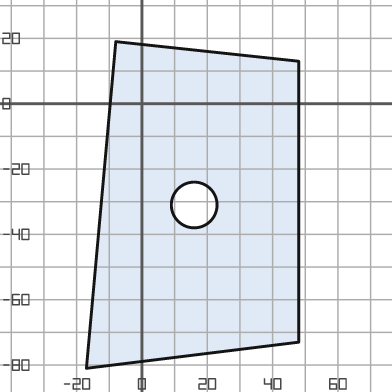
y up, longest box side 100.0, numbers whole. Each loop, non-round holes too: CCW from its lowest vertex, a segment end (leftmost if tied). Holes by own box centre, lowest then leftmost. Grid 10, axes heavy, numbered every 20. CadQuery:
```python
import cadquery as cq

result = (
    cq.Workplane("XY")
    .moveTo(-17.0, -81.0)
    .lineTo(48.0, -73.0)
    .lineTo(48.0, 13.0)
    .lineTo(-8.0, 19.0)
    .close()
    .moveTo(16.0, -31.0)
    .circle(7.0)
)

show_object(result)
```